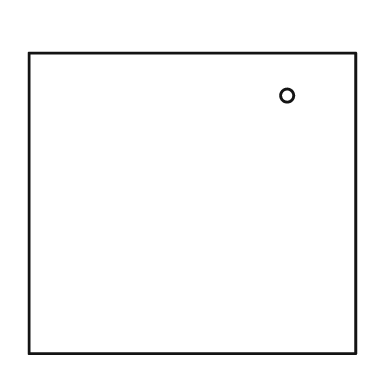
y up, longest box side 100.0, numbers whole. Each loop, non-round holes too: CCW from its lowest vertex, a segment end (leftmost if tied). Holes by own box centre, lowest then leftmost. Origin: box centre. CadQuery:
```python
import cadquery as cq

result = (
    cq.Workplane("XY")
    .moveTo(-50.0, -46.0)
    .lineTo(50.0, -46.0)
    .lineTo(50.0, 46.0)
    .lineTo(-50.0, 46.0)
    .close()
    .moveTo(29.0, 33.0)
    .circle(2.0)
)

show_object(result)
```